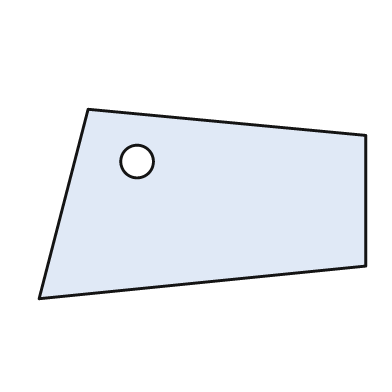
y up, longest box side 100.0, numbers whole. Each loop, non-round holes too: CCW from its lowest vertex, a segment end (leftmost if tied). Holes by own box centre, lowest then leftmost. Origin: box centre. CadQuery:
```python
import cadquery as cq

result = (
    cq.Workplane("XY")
    .moveTo(-50.0, -29.0)
    .lineTo(50.0, -19.0)
    .lineTo(50.0, 21.0)
    .lineTo(-35.0, 29.0)
    .close()
    .moveTo(-20.0, 13.0)
    .circle(5.0)
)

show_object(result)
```